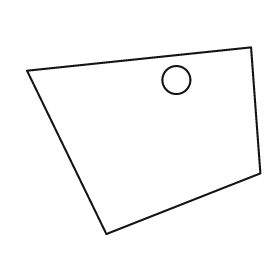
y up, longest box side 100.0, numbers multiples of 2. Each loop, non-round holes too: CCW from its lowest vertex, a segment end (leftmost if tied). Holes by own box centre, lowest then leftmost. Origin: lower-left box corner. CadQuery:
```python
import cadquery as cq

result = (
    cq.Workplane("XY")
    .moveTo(34.0, 0.0)
    .lineTo(100.0, 26.0)
    .lineTo(96.0, 80.0)
    .lineTo(0.0, 70.0)
    .close()
    .moveTo(64.0, 66.0)
    .circle(6.0)
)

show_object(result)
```